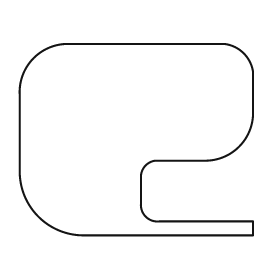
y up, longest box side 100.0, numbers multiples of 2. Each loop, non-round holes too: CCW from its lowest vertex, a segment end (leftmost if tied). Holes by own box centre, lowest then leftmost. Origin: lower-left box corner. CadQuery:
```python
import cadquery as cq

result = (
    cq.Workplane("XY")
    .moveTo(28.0, 0.0)
    .lineTo(100.0, 0.0)
    .lineTo(100.0, 6.0)
    .lineTo(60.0, 6.0)
    .threePointArc((54.0, 8.0), (52.0, 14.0))
    .lineTo(52.0, 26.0)
    .threePointArc((54.0, 30.0), (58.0, 32.0))
    .lineTo(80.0, 32.0)
    .threePointArc((94.0, 38.0), (100.0, 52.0))
    .lineTo(100.0, 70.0)
    .threePointArc((96.0, 78.0), (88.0, 82.0))
    .lineTo(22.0, 82.0)
    .threePointArc((6.0, 76.0), (0.0, 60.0))
    .lineTo(0.0, 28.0)
    .threePointArc((8.0, 8.0), (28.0, 0.0))
    .close()
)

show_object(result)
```